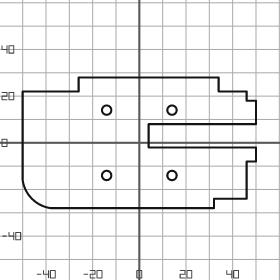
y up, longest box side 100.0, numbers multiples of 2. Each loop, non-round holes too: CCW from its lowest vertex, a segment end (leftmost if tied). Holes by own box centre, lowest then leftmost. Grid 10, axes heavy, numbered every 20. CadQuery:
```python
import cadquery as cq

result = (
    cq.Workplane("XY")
    .moveTo(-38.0, -28.0)
    .lineTo(32.0, -28.0)
    .lineTo(32.0, -24.0)
    .lineTo(46.0, -24.0)
    .lineTo(46.0, -8.0)
    .lineTo(50.0, -8.0)
    .lineTo(50.0, -2.0)
    .lineTo(4.0, -2.0)
    .lineTo(4.0, 8.0)
    .lineTo(50.0, 8.0)
    .lineTo(50.0, 18.0)
    .lineTo(46.0, 18.0)
    .lineTo(46.0, 22.0)
    .lineTo(34.0, 22.0)
    .lineTo(34.0, 28.0)
    .lineTo(-26.0, 28.0)
    .lineTo(-26.0, 22.0)
    .lineTo(-50.0, 22.0)
    .lineTo(-50.0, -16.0)
    .threePointArc((-46.0, -24.0), (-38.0, -28.0))
    .close()
    .moveTo(-14.0, -14.0)
    .circle(2.0)
    .moveTo(14.0, -14.0)
    .circle(2.0)
    .moveTo(-14.0, 14.0)
    .circle(2.0)
    .moveTo(14.0, 14.0)
    .circle(2.0)
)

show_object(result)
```